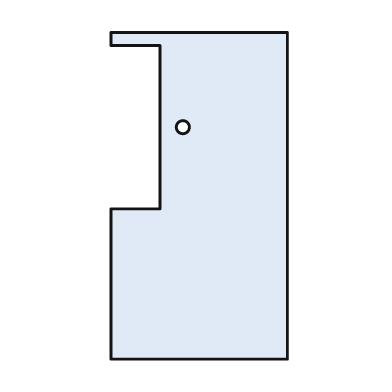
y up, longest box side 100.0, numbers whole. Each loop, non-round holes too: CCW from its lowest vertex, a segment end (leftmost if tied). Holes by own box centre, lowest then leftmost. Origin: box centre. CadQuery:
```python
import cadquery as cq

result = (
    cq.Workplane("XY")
    .moveTo(-27.0, -50.0)
    .lineTo(27.0, -50.0)
    .lineTo(27.0, 50.0)
    .lineTo(-27.0, 50.0)
    .lineTo(-27.0, 46.0)
    .lineTo(-12.0, 46.0)
    .lineTo(-12.0, -4.0)
    .lineTo(-27.0, -4.0)
    .close()
    .moveTo(-5.0, 21.0)
    .circle(2.0)
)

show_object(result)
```